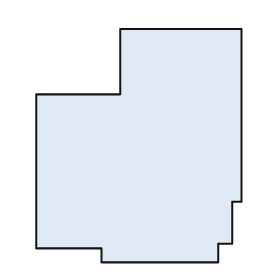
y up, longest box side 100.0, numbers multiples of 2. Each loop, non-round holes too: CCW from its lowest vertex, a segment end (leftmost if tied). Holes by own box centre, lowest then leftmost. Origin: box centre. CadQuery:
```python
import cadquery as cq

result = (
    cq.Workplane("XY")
    .moveTo(-16.0, -50.0)
    .lineTo(34.0, -50.0)
    .lineTo(34.0, -42.0)
    .lineTo(40.0, -42.0)
    .lineTo(40.0, -24.0)
    .lineTo(44.0, -24.0)
    .lineTo(44.0, 50.0)
    .lineTo(-8.0, 50.0)
    .lineTo(-8.0, 22.0)
    .lineTo(-44.0, 22.0)
    .lineTo(-44.0, -44.0)
    .lineTo(-16.0, -44.0)
    .close()
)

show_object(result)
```